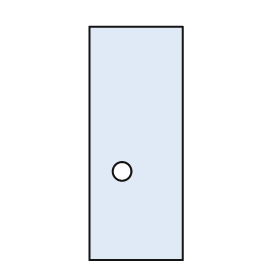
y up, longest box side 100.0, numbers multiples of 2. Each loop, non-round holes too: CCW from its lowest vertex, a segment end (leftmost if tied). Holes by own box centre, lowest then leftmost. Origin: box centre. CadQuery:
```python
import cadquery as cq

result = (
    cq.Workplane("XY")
    .moveTo(-20.0, -50.0)
    .lineTo(20.0, -50.0)
    .lineTo(20.0, 50.0)
    .lineTo(-20.0, 50.0)
    .close()
    .moveTo(-6.0, -12.0)
    .circle(4.0)
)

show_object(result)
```